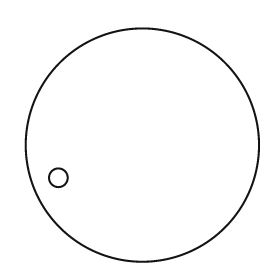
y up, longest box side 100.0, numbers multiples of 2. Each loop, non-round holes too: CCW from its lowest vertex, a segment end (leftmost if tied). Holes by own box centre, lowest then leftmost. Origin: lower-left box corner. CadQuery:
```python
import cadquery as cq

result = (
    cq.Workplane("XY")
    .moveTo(50.0, 50.0)
    .circle(50.0)
    .moveTo(14.0, 36.0)
    .circle(4.0)
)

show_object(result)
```